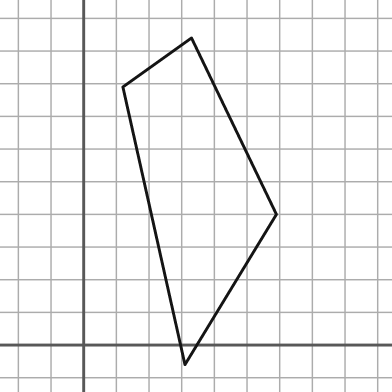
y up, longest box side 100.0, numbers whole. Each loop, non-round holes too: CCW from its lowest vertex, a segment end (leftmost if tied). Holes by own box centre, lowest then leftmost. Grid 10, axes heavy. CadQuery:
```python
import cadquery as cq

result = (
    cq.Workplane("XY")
    .moveTo(31.0, -6.0)
    .lineTo(59.0, 40.0)
    .lineTo(33.0, 94.0)
    .lineTo(12.0, 79.0)
    .close()
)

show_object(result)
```